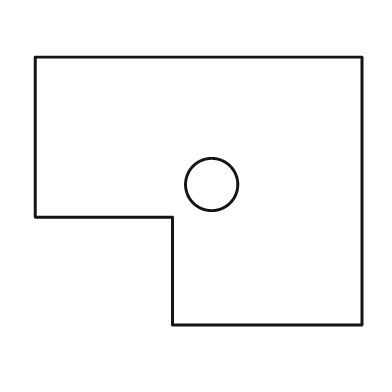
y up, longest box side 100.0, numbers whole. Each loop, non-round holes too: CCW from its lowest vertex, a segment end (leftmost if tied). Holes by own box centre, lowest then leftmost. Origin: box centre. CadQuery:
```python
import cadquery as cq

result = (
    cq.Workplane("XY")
    .moveTo(-8.0, -41.0)
    .lineTo(50.0, -41.0)
    .lineTo(50.0, 41.0)
    .lineTo(-50.0, 41.0)
    .lineTo(-50.0, -8.0)
    .lineTo(-8.0, -8.0)
    .close()
    .moveTo(4.0, 2.0)
    .circle(8.0)
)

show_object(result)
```